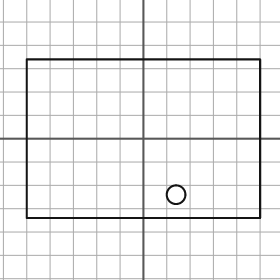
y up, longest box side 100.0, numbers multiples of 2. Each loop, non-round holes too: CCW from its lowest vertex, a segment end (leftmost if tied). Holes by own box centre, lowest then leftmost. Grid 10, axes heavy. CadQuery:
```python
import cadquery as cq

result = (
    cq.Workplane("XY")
    .moveTo(-50.0, -34.0)
    .lineTo(50.0, -34.0)
    .lineTo(50.0, 34.0)
    .lineTo(-50.0, 34.0)
    .close()
    .moveTo(14.0, -24.0)
    .circle(4.0)
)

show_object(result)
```